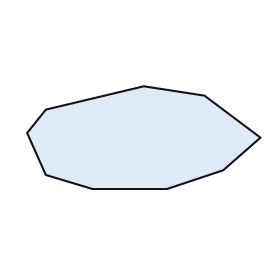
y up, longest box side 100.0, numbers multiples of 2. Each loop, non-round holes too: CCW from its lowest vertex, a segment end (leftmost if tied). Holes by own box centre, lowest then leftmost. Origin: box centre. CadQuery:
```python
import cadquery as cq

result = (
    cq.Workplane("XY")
    .moveTo(-22.0, -22.0)
    .lineTo(10.0, -22.0)
    .lineTo(34.0, -14.0)
    .lineTo(50.0, 0.0)
    .lineTo(26.0, 18.0)
    .lineTo(0.0, 22.0)
    .lineTo(-42.0, 12.0)
    .lineTo(-50.0, 2.0)
    .lineTo(-42.0, -16.0)
    .close()
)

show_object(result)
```